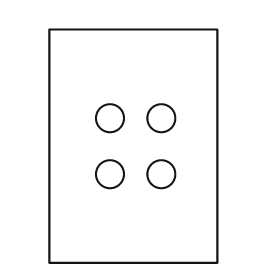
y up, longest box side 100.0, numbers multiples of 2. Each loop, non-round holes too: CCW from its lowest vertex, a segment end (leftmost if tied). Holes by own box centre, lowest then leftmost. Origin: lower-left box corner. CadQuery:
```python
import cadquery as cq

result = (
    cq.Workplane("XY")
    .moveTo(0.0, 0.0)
    .lineTo(72.0, 0.0)
    .lineTo(72.0, 100.0)
    .lineTo(0.0, 100.0)
    .close()
    .moveTo(26.0, 38.0)
    .circle(6.0)
    .moveTo(48.0, 38.0)
    .circle(6.0)
    .moveTo(26.0, 62.0)
    .circle(6.0)
    .moveTo(48.0, 62.0)
    .circle(6.0)
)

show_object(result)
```